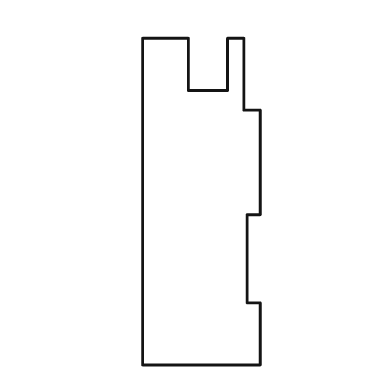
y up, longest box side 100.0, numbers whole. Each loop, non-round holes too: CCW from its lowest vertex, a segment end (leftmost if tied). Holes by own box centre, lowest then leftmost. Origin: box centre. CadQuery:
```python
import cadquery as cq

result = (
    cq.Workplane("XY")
    .moveTo(-18.0, -50.0)
    .lineTo(18.0, -50.0)
    .lineTo(18.0, -31.0)
    .lineTo(14.0, -31.0)
    .lineTo(14.0, -4.0)
    .lineTo(18.0, -4.0)
    .lineTo(18.0, 28.0)
    .lineTo(13.0, 28.0)
    .lineTo(13.0, 50.0)
    .lineTo(8.0, 50.0)
    .lineTo(8.0, 34.0)
    .lineTo(-4.0, 34.0)
    .lineTo(-4.0, 50.0)
    .lineTo(-18.0, 50.0)
    .close()
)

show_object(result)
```